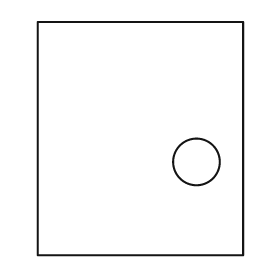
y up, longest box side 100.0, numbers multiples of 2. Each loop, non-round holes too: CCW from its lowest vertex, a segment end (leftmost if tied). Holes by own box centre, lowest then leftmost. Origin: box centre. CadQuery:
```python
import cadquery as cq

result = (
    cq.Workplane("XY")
    .moveTo(-44.0, -50.0)
    .lineTo(44.0, -50.0)
    .lineTo(44.0, 50.0)
    .lineTo(-44.0, 50.0)
    .close()
    .moveTo(24.0, -10.0)
    .circle(10.0)
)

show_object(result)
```